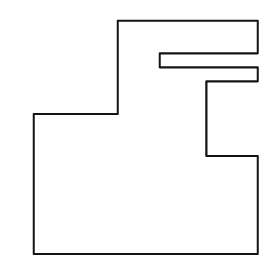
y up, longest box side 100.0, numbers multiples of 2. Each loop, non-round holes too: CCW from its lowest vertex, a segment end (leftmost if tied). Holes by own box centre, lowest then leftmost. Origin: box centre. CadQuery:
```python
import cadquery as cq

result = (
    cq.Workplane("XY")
    .moveTo(-48.0, -50.0)
    .lineTo(48.0, -50.0)
    .lineTo(48.0, -8.0)
    .lineTo(26.0, -8.0)
    .lineTo(26.0, 24.0)
    .lineTo(48.0, 24.0)
    .lineTo(48.0, 30.0)
    .lineTo(6.0, 30.0)
    .lineTo(6.0, 36.0)
    .lineTo(48.0, 36.0)
    .lineTo(48.0, 50.0)
    .lineTo(-12.0, 50.0)
    .lineTo(-12.0, 10.0)
    .lineTo(-48.0, 10.0)
    .close()
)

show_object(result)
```